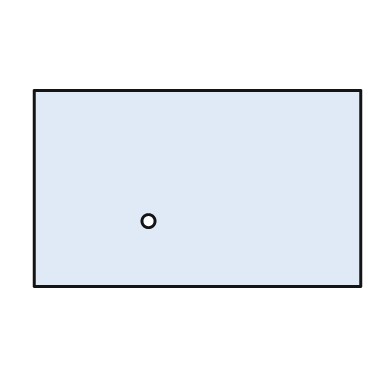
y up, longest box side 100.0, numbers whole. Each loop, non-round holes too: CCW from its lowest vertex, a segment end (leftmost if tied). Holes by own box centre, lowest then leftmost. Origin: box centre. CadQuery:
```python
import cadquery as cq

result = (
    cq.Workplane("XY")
    .moveTo(-50.0, -30.0)
    .lineTo(50.0, -30.0)
    .lineTo(50.0, 30.0)
    .lineTo(-50.0, 30.0)
    .close()
    .moveTo(-15.0, -10.0)
    .circle(2.0)
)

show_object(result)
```